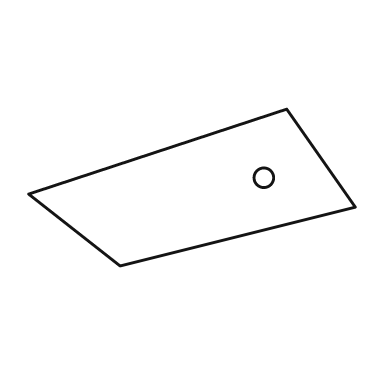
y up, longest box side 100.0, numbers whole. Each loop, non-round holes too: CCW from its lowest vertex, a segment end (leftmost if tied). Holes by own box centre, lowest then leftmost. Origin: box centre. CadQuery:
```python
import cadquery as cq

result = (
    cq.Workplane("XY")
    .moveTo(-22.0, -24.0)
    .lineTo(50.0, -6.0)
    .lineTo(29.0, 24.0)
    .lineTo(-50.0, -2.0)
    .close()
    .moveTo(22.0, 3.0)
    .circle(3.0)
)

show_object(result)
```